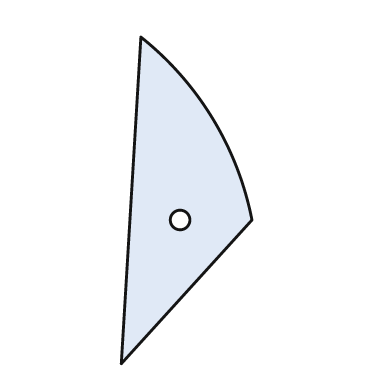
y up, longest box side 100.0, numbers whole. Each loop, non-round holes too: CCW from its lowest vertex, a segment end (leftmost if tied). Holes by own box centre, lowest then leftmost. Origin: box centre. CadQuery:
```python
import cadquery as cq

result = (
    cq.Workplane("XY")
    .moveTo(-20.0, -50.0)
    .lineTo(20.0, -6.0)
    .threePointArc((8.0, 25.0), (-14.0, 50.0))
    .close()
    .moveTo(-2.0, -6.0)
    .circle(3.0)
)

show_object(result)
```